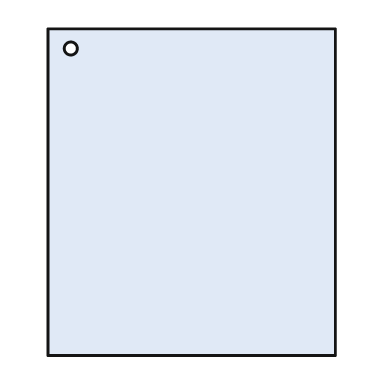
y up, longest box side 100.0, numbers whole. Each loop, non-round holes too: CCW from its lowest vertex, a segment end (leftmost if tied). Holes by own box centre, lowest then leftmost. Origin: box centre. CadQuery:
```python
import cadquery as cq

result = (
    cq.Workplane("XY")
    .moveTo(-44.0, -50.0)
    .lineTo(44.0, -50.0)
    .lineTo(44.0, 50.0)
    .lineTo(-44.0, 50.0)
    .close()
    .moveTo(-37.0, 44.0)
    .circle(2.0)
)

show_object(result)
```